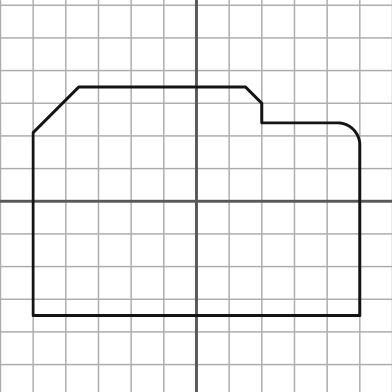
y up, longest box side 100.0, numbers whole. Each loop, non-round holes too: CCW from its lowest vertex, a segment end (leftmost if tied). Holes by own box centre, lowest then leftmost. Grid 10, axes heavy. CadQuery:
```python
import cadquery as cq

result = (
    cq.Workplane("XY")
    .moveTo(-50.0, -35.0)
    .lineTo(50.0, -35.0)
    .lineTo(50.0, 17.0)
    .threePointArc((48.0, 22.0), (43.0, 24.0))
    .lineTo(20.0, 24.0)
    .lineTo(20.0, 30.0)
    .lineTo(15.0, 35.0)
    .lineTo(-36.0, 35.0)
    .lineTo(-50.0, 21.0)
    .close()
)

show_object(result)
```